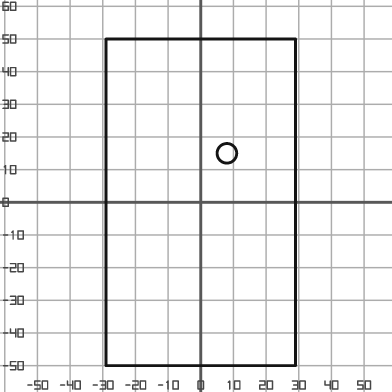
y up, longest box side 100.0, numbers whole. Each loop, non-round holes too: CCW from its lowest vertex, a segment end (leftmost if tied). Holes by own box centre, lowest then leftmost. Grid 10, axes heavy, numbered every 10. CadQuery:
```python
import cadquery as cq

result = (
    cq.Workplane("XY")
    .moveTo(-29.0, -50.0)
    .lineTo(29.0, -50.0)
    .lineTo(29.0, 50.0)
    .lineTo(-29.0, 50.0)
    .close()
    .moveTo(8.0, 15.0)
    .circle(3.0)
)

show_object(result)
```